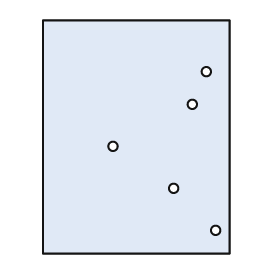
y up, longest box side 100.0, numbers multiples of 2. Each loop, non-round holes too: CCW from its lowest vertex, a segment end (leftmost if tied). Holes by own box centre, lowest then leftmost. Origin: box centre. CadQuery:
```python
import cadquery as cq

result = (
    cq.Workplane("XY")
    .moveTo(-40.0, -50.0)
    .lineTo(40.0, -50.0)
    .lineTo(40.0, 50.0)
    .lineTo(-40.0, 50.0)
    .close()
    .moveTo(34.0, -40.0)
    .circle(2.0)
    .moveTo(16.0, -22.0)
    .circle(2.0)
    .moveTo(-10.0, -4.0)
    .circle(2.0)
    .moveTo(24.0, 14.0)
    .circle(2.0)
    .moveTo(30.0, 28.0)
    .circle(2.0)
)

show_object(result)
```